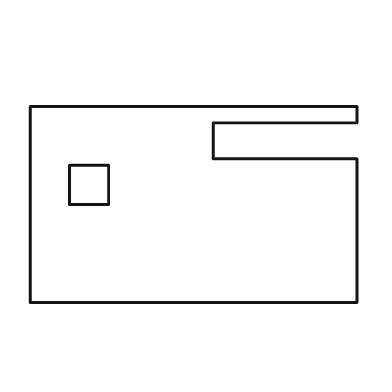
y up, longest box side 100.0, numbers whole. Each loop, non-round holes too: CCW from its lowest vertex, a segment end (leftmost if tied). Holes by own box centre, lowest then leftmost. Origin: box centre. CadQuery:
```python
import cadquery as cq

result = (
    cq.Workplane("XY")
    .moveTo(-50.0, -30.0)
    .lineTo(50.0, -30.0)
    .lineTo(50.0, 14.0)
    .lineTo(6.0, 14.0)
    .lineTo(6.0, 25.0)
    .lineTo(50.0, 25.0)
    .lineTo(50.0, 30.0)
    .lineTo(-50.0, 30.0)
    .close()
    .moveTo(-38.0, 0.0)
    .lineTo(-26.0, 0.0)
    .lineTo(-26.0, 12.0)
    .lineTo(-38.0, 12.0)
    .close()
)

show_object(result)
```